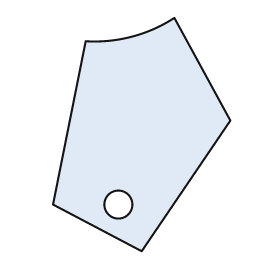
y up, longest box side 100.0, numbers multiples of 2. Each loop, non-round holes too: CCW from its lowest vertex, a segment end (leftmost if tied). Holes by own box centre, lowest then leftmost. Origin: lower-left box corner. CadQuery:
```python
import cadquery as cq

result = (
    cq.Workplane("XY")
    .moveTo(38.0, 0.0)
    .lineTo(76.0, 56.0)
    .lineTo(52.0, 100.0)
    .threePointArc((34.0, 92.0), (14.0, 90.0))
    .lineTo(0.0, 20.0)
    .close()
    .moveTo(28.0, 20.0)
    .circle(6.0)
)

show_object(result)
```